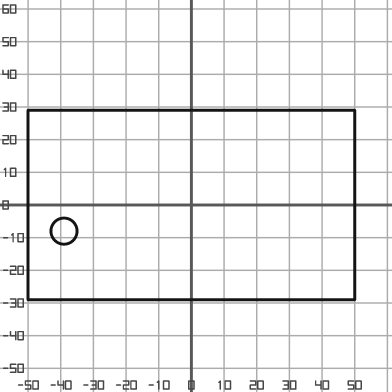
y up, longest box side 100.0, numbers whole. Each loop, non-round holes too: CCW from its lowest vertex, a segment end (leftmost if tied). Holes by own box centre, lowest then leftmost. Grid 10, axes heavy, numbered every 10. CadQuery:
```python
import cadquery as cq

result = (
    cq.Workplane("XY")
    .moveTo(-50.0, -29.0)
    .lineTo(50.0, -29.0)
    .lineTo(50.0, 29.0)
    .lineTo(-50.0, 29.0)
    .close()
    .moveTo(-39.0, -8.0)
    .circle(4.0)
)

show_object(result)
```